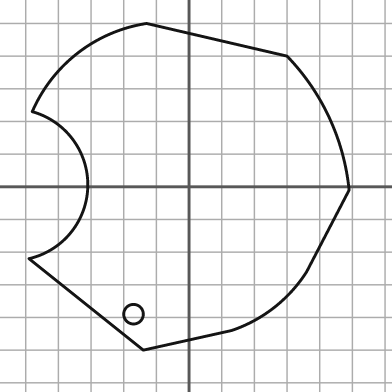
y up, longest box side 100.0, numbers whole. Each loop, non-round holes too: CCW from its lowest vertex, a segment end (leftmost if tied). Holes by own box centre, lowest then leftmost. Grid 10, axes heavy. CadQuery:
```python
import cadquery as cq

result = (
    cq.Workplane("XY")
    .moveTo(-14.0, -50.0)
    .lineTo(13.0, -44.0)
    .threePointArc((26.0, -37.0), (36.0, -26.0))
    .lineTo(49.0, -1.0)
    .threePointArc((43.0, 21.0), (30.0, 40.0))
    .lineTo(-13.0, 50.0)
    .threePointArc((-34.0, 41.0), (-48.0, 23.0))
    .threePointArc((-31.0, 0.0), (-49.0, -22.0))
    .close()
    .moveTo(-17.0, -39.0)
    .circle(3.0)
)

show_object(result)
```